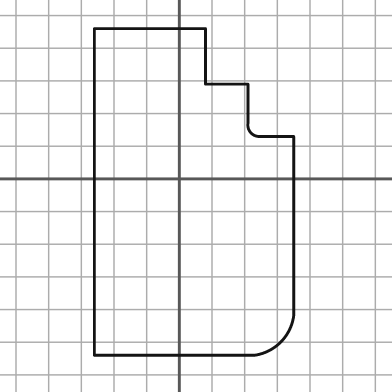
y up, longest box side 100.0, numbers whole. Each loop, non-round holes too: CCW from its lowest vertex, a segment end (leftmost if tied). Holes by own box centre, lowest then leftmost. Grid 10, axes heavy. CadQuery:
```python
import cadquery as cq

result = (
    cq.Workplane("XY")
    .moveTo(-26.0, -54.0)
    .lineTo(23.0, -54.0)
    .threePointArc((31.0, -50.0), (35.0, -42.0))
    .lineTo(35.0, 13.0)
    .lineTo(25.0, 13.0)
    .threePointArc((22.0, 14.0), (21.0, 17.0))
    .lineTo(21.0, 29.0)
    .lineTo(8.0, 29.0)
    .lineTo(8.0, 46.0)
    .lineTo(-26.0, 46.0)
    .close()
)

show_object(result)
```